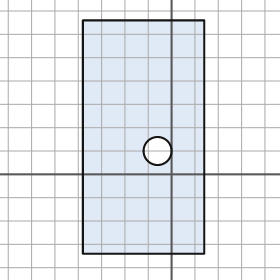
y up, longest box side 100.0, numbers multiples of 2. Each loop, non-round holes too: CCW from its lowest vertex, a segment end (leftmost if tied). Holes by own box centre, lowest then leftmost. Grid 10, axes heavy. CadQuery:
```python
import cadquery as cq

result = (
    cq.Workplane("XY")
    .moveTo(-38.0, -34.0)
    .lineTo(14.0, -34.0)
    .lineTo(14.0, 66.0)
    .lineTo(-38.0, 66.0)
    .close()
    .moveTo(-6.0, 10.0)
    .circle(6.0)
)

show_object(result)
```